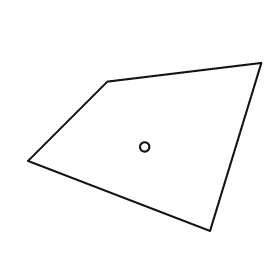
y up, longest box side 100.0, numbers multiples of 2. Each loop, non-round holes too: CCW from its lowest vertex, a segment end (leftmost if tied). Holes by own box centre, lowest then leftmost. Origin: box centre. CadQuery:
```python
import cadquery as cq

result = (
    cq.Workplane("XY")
    .moveTo(28.0, -36.0)
    .lineTo(50.0, 36.0)
    .lineTo(-16.0, 28.0)
    .lineTo(-50.0, -6.0)
    .close()
    .moveTo(0.0, 0.0)
    .circle(2.0)
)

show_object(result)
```